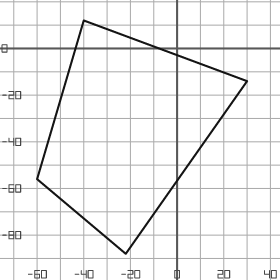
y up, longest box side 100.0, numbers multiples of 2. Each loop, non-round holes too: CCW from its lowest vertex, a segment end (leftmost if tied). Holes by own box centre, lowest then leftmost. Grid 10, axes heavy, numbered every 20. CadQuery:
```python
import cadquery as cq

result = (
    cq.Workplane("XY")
    .moveTo(-22.0, -88.0)
    .lineTo(30.0, -14.0)
    .lineTo(-40.0, 12.0)
    .lineTo(-60.0, -56.0)
    .close()
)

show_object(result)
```